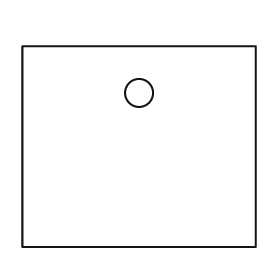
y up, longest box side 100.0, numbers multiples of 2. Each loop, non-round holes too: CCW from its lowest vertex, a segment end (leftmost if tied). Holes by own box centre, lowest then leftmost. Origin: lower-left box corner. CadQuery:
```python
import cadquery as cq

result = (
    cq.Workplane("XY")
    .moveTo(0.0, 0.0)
    .lineTo(100.0, 0.0)
    .lineTo(100.0, 86.0)
    .lineTo(0.0, 86.0)
    .close()
    .moveTo(50.0, 66.0)
    .circle(6.0)
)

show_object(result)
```